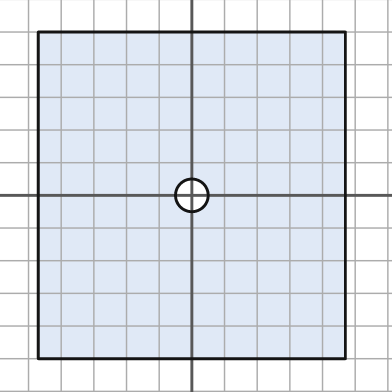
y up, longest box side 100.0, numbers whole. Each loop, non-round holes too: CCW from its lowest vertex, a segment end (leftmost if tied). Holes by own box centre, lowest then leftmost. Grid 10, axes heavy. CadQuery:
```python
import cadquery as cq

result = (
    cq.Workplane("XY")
    .moveTo(-47.0, -50.0)
    .lineTo(47.0, -50.0)
    .lineTo(47.0, 50.0)
    .lineTo(-47.0, 50.0)
    .close()
    .moveTo(0.0, 0.0)
    .circle(5.0)
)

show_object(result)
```